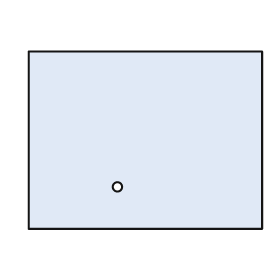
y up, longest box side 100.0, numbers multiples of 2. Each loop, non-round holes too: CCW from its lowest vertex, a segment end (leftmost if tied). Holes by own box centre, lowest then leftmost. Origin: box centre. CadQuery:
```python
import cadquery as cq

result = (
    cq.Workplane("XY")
    .moveTo(-50.0, -38.0)
    .lineTo(50.0, -38.0)
    .lineTo(50.0, 38.0)
    .lineTo(-50.0, 38.0)
    .close()
    .moveTo(-12.0, -20.0)
    .circle(2.0)
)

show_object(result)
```